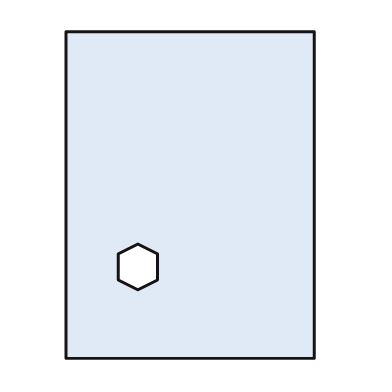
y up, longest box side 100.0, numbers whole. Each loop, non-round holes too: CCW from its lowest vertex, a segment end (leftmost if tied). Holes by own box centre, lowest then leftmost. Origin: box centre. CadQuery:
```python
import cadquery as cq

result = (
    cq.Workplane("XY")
    .moveTo(-38.0, -50.0)
    .lineTo(38.0, -50.0)
    .lineTo(38.0, 50.0)
    .lineTo(-38.0, 50.0)
    .close()
    .moveTo(-16.0, -29.0)
    .lineTo(-10.0, -26.0)
    .lineTo(-10.0, -18.0)
    .lineTo(-16.0, -15.0)
    .lineTo(-22.0, -18.0)
    .lineTo(-22.0, -26.0)
    .close()
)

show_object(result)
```